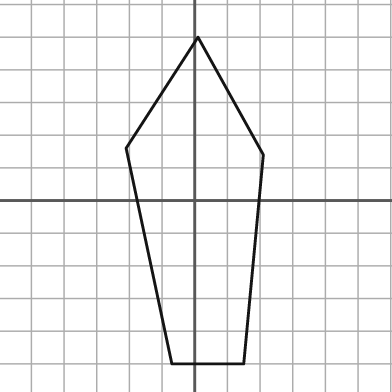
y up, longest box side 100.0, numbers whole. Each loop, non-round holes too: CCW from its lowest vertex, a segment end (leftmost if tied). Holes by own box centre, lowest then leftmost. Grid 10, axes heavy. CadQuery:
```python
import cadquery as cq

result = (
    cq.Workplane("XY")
    .moveTo(-7.0, -50.0)
    .lineTo(15.0, -50.0)
    .lineTo(21.0, 14.0)
    .lineTo(1.0, 50.0)
    .lineTo(-21.0, 16.0)
    .close()
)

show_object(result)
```